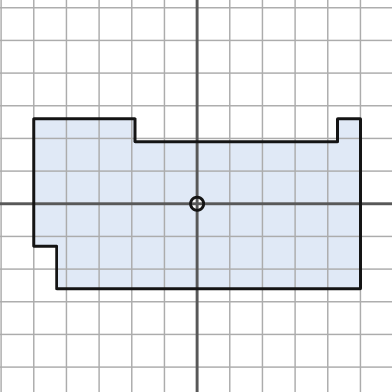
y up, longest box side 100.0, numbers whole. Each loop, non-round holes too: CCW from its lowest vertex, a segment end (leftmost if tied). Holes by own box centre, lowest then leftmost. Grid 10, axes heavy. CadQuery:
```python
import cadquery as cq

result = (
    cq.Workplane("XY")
    .moveTo(-43.0, -26.0)
    .lineTo(50.0, -26.0)
    .lineTo(50.0, 26.0)
    .lineTo(43.0, 26.0)
    .lineTo(43.0, 19.0)
    .lineTo(-19.0, 19.0)
    .lineTo(-19.0, 26.0)
    .lineTo(-50.0, 26.0)
    .lineTo(-50.0, -13.0)
    .lineTo(-43.0, -13.0)
    .close()
    .moveTo(0.0, 0.0)
    .circle(2.0)
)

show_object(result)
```